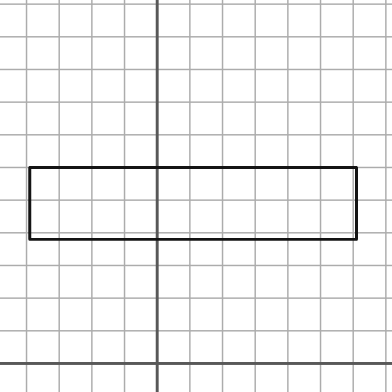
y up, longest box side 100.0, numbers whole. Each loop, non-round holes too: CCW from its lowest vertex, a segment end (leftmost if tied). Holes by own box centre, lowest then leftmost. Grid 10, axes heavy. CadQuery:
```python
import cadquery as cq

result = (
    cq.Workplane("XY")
    .moveTo(-39.0, 38.0)
    .lineTo(61.0, 38.0)
    .lineTo(61.0, 60.0)
    .lineTo(-39.0, 60.0)
    .close()
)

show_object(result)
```